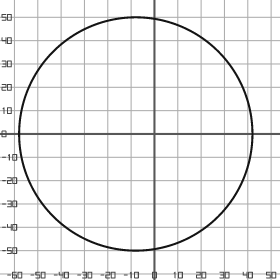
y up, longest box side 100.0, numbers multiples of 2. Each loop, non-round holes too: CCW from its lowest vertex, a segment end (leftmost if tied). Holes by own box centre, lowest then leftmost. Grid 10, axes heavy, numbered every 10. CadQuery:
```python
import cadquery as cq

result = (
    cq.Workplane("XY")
    .moveTo(-8.0, 0.0)
    .circle(50.0)
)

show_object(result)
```